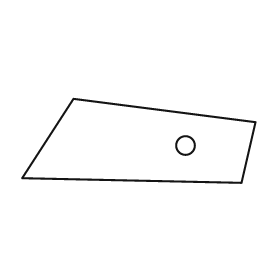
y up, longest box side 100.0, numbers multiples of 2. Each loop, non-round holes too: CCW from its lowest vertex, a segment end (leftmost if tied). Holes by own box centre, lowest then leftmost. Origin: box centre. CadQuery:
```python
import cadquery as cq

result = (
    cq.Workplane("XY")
    .moveTo(44.0, -18.0)
    .lineTo(50.0, 8.0)
    .lineTo(-28.0, 18.0)
    .lineTo(-50.0, -16.0)
    .close()
    .moveTo(20.0, -2.0)
    .circle(4.0)
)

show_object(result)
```